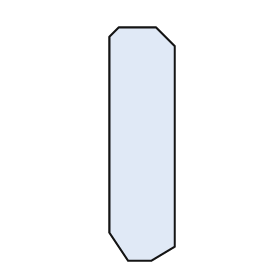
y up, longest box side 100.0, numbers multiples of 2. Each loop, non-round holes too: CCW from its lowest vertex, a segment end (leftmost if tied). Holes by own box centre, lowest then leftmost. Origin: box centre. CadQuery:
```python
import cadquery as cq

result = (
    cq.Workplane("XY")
    .moveTo(-6.0, -50.0)
    .lineTo(4.0, -50.0)
    .lineTo(14.0, -44.0)
    .lineTo(14.0, 42.0)
    .lineTo(6.0, 50.0)
    .lineTo(-10.0, 50.0)
    .lineTo(-14.0, 46.0)
    .lineTo(-14.0, -38.0)
    .close()
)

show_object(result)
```